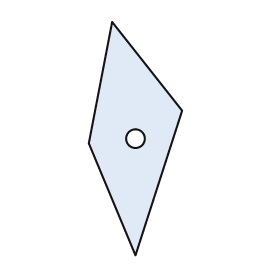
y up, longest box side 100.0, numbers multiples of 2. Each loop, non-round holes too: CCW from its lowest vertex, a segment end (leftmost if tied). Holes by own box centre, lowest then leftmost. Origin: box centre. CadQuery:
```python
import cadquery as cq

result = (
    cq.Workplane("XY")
    .moveTo(0.0, -50.0)
    .lineTo(20.0, 12.0)
    .lineTo(-10.0, 50.0)
    .lineTo(-20.0, -2.0)
    .close()
    .moveTo(0.0, 0.0)
    .circle(4.0)
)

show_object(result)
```